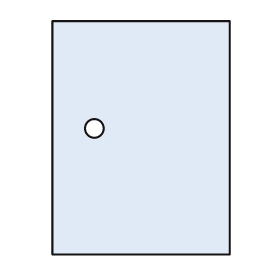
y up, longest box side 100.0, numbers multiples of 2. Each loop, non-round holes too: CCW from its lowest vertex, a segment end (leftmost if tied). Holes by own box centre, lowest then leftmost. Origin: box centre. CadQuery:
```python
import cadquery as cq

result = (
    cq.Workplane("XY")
    .moveTo(-38.0, -50.0)
    .lineTo(38.0, -50.0)
    .lineTo(38.0, 50.0)
    .lineTo(-38.0, 50.0)
    .close()
    .moveTo(-20.0, 4.0)
    .circle(4.0)
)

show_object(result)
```